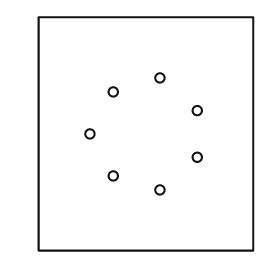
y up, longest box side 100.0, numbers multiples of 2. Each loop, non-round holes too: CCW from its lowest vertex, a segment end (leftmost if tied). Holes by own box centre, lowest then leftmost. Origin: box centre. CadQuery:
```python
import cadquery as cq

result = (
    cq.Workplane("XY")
    .moveTo(-46.0, -50.0)
    .lineTo(46.0, -50.0)
    .lineTo(46.0, 50.0)
    .lineTo(-46.0, 50.0)
    .close()
    .moveTo(6.0, -24.0)
    .circle(2.0)
    .moveTo(-14.0, -18.0)
    .circle(2.0)
    .moveTo(22.0, -10.0)
    .circle(2.0)
    .moveTo(-24.0, 0.0)
    .circle(2.0)
    .moveTo(22.0, 10.0)
    .circle(2.0)
    .moveTo(-14.0, 18.0)
    .circle(2.0)
    .moveTo(6.0, 24.0)
    .circle(2.0)
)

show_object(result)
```